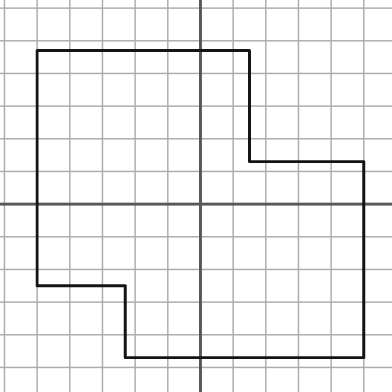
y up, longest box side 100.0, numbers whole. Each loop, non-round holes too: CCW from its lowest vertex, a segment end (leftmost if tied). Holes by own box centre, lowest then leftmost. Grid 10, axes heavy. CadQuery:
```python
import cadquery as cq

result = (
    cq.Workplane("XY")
    .moveTo(-23.0, -47.0)
    .lineTo(50.0, -47.0)
    .lineTo(50.0, 13.0)
    .lineTo(15.0, 13.0)
    .lineTo(15.0, 47.0)
    .lineTo(-50.0, 47.0)
    .lineTo(-50.0, -25.0)
    .lineTo(-23.0, -25.0)
    .close()
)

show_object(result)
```